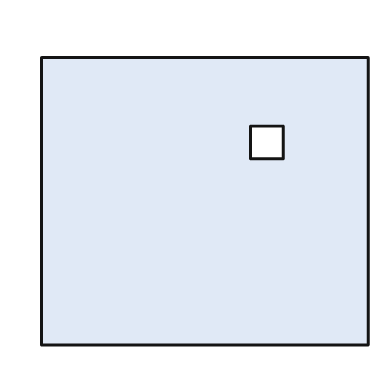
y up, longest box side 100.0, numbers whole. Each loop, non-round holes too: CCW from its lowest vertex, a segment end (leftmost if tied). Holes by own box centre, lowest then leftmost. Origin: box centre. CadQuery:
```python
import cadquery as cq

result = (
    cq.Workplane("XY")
    .moveTo(-50.0, -44.0)
    .lineTo(50.0, -44.0)
    .lineTo(50.0, 44.0)
    .lineTo(-50.0, 44.0)
    .close()
    .moveTo(14.0, 13.0)
    .lineTo(24.0, 13.0)
    .lineTo(24.0, 23.0)
    .lineTo(14.0, 23.0)
    .close()
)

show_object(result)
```